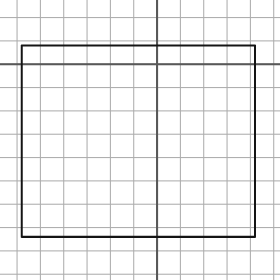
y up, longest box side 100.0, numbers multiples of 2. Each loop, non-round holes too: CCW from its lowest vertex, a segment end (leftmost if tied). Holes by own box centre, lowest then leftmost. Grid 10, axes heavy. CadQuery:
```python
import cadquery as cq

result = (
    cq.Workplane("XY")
    .moveTo(-58.0, -74.0)
    .lineTo(42.0, -74.0)
    .lineTo(42.0, 8.0)
    .lineTo(-58.0, 8.0)
    .close()
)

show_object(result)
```